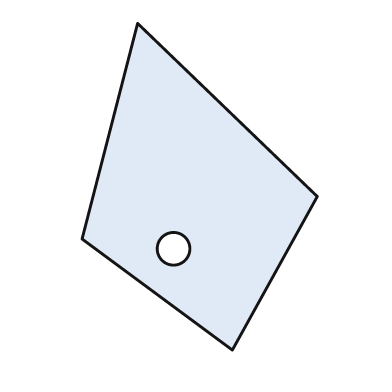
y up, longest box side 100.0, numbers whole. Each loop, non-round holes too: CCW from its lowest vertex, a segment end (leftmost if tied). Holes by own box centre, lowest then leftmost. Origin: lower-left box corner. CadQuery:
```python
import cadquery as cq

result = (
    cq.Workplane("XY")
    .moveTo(46.0, 0.0)
    .lineTo(72.0, 47.0)
    .lineTo(17.0, 100.0)
    .lineTo(0.0, 34.0)
    .close()
    .moveTo(28.0, 31.0)
    .circle(5.0)
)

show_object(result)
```